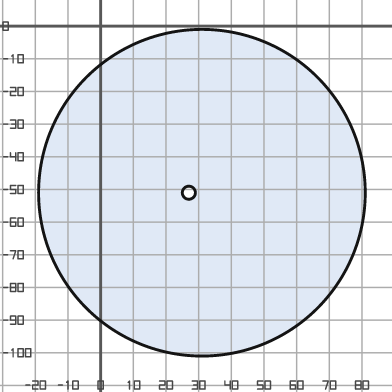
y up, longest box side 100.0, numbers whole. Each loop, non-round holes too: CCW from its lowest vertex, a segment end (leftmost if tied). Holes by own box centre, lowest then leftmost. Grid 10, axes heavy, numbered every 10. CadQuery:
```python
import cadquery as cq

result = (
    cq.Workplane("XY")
    .moveTo(31.0, -51.0)
    .circle(50.0)
    .moveTo(27.0, -51.0)
    .circle(2.0)
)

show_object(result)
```